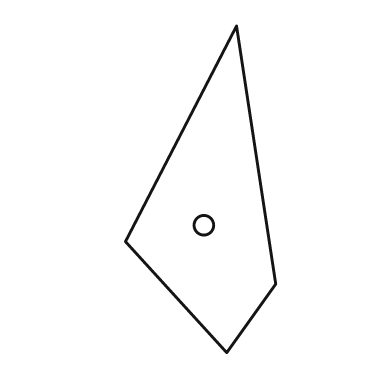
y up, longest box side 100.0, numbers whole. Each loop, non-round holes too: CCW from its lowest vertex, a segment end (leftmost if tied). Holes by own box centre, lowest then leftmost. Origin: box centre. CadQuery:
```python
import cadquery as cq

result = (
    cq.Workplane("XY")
    .moveTo(8.0, -50.0)
    .lineTo(23.0, -29.0)
    .lineTo(11.0, 50.0)
    .lineTo(-23.0, -16.0)
    .close()
    .moveTo(1.0, -11.0)
    .circle(3.0)
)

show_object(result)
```